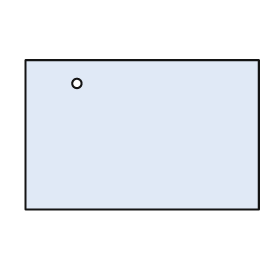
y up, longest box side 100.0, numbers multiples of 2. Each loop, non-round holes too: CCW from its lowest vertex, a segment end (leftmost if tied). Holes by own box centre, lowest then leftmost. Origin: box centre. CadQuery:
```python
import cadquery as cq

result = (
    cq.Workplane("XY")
    .moveTo(-50.0, -32.0)
    .lineTo(50.0, -32.0)
    .lineTo(50.0, 32.0)
    .lineTo(-50.0, 32.0)
    .close()
    .moveTo(-28.0, 22.0)
    .circle(2.0)
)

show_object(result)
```